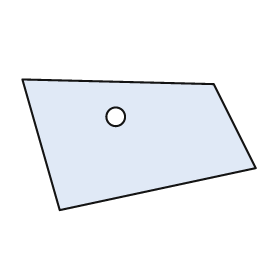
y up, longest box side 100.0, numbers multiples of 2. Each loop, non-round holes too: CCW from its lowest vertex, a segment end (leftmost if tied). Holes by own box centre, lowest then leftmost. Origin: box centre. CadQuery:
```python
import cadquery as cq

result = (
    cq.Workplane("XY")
    .moveTo(-34.0, -28.0)
    .lineTo(50.0, -10.0)
    .lineTo(32.0, 26.0)
    .lineTo(-50.0, 28.0)
    .close()
    .moveTo(-10.0, 12.0)
    .circle(4.0)
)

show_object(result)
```